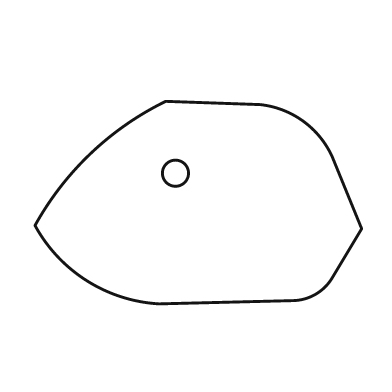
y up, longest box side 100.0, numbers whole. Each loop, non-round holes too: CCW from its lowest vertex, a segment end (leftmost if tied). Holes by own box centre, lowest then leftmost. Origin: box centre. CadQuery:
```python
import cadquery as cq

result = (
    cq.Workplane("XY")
    .moveTo(-12.0, -31.0)
    .lineTo(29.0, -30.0)
    .threePointArc((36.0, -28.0), (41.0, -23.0))
    .lineTo(50.0, -8.0)
    .lineTo(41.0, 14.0)
    .threePointArc((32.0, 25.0), (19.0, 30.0))
    .lineTo(-10.0, 31.0)
    .threePointArc((-33.0, 15.0), (-50.0, -7.0))
    .threePointArc((-34.0, -24.0), (-12.0, -31.0))
    .close()
    .moveTo(-7.0, 9.0)
    .circle(4.0)
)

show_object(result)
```